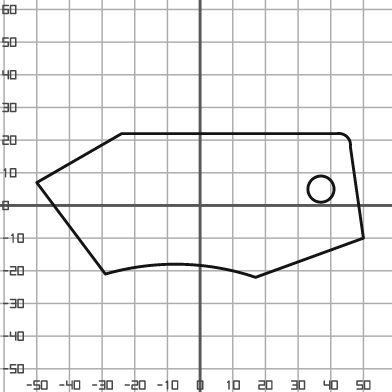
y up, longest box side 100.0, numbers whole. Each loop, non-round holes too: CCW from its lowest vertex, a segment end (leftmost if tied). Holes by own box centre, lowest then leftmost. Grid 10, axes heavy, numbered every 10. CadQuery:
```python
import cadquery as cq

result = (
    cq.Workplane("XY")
    .moveTo(17.0, -22.0)
    .lineTo(50.0, -10.0)
    .lineTo(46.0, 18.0)
    .threePointArc((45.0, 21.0), (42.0, 22.0))
    .lineTo(-24.0, 22.0)
    .lineTo(-50.0, 7.0)
    .lineTo(-29.0, -21.0)
    .threePointArc((-6.0, -18.0), (17.0, -22.0))
    .close()
    .moveTo(37.0, 5.0)
    .circle(4.0)
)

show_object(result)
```